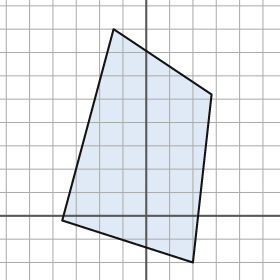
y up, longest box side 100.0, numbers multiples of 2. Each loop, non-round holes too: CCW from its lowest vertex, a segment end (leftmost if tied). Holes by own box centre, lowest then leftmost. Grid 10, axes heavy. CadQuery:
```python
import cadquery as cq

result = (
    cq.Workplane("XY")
    .moveTo(20.0, -20.0)
    .lineTo(28.0, 52.0)
    .lineTo(-14.0, 80.0)
    .lineTo(-36.0, -2.0)
    .close()
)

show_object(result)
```